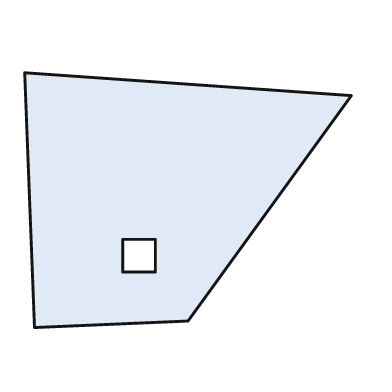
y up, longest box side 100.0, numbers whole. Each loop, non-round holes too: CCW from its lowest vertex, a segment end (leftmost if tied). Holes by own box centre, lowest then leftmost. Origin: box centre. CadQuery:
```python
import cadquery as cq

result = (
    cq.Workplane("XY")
    .moveTo(-47.0, -39.0)
    .lineTo(0.0, -37.0)
    .lineTo(50.0, 32.0)
    .lineTo(-50.0, 39.0)
    .close()
    .moveTo(-20.0, -22.0)
    .lineTo(-10.0, -22.0)
    .lineTo(-10.0, -12.0)
    .lineTo(-20.0, -12.0)
    .close()
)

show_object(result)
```